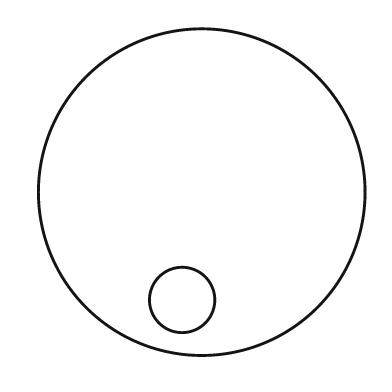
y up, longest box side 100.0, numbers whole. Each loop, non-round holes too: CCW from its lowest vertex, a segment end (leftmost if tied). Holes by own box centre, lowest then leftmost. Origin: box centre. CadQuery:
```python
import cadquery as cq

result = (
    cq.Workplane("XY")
    .moveTo(0.0, 0.0)
    .circle(50.0)
    .moveTo(-6.0, -33.0)
    .circle(10.0)
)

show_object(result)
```